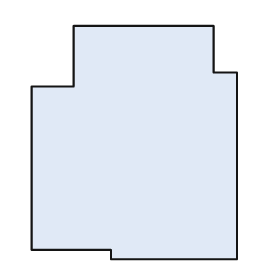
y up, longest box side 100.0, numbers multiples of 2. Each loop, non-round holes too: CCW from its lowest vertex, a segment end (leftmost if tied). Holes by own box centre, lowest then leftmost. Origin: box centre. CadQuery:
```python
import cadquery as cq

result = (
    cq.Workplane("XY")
    .moveTo(-10.0, -50.0)
    .lineTo(44.0, -50.0)
    .lineTo(44.0, 30.0)
    .lineTo(34.0, 30.0)
    .lineTo(34.0, 50.0)
    .lineTo(-26.0, 50.0)
    .lineTo(-26.0, 24.0)
    .lineTo(-44.0, 24.0)
    .lineTo(-44.0, -46.0)
    .lineTo(-10.0, -46.0)
    .close()
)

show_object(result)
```